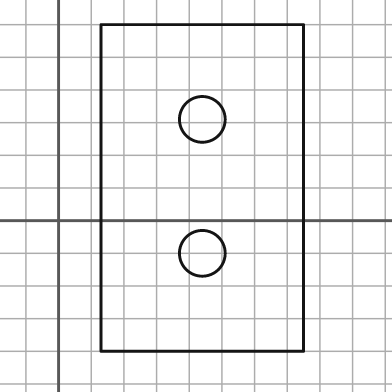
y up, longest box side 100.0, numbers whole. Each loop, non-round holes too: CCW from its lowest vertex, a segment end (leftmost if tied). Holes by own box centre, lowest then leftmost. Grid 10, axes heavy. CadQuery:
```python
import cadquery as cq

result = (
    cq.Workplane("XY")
    .moveTo(13.0, -40.0)
    .lineTo(75.0, -40.0)
    .lineTo(75.0, 60.0)
    .lineTo(13.0, 60.0)
    .close()
    .moveTo(44.0, -10.0)
    .circle(7.0)
    .moveTo(44.0, 31.0)
    .circle(7.0)
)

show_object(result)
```